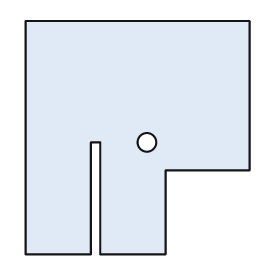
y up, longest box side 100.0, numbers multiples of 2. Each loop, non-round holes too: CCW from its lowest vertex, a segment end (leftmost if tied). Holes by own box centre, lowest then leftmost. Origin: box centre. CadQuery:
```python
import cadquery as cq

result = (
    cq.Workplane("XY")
    .moveTo(-48.0, -50.0)
    .lineTo(-20.0, -50.0)
    .lineTo(-20.0, -2.0)
    .lineTo(-16.0, -2.0)
    .lineTo(-16.0, -50.0)
    .lineTo(12.0, -50.0)
    .lineTo(12.0, -14.0)
    .lineTo(48.0, -14.0)
    .lineTo(48.0, 50.0)
    .lineTo(-48.0, 50.0)
    .close()
    .moveTo(4.0, -2.0)
    .circle(4.0)
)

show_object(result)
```